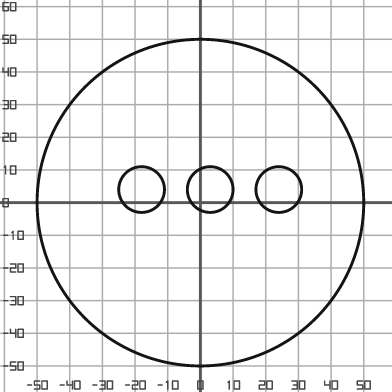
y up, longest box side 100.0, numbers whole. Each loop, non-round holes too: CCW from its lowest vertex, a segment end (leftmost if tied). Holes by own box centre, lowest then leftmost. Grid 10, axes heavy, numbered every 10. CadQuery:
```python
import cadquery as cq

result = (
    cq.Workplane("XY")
    .moveTo(0.0, 0.0)
    .circle(50.0)
    .moveTo(-18.0, 4.0)
    .circle(7.0)
    .moveTo(3.0, 4.0)
    .circle(7.0)
    .moveTo(24.0, 4.0)
    .circle(7.0)
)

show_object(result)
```